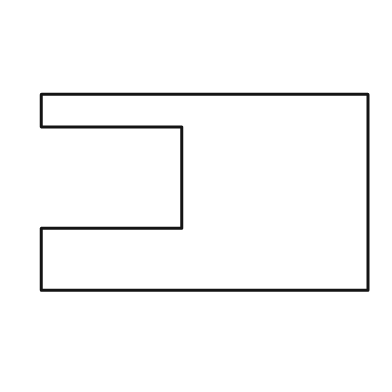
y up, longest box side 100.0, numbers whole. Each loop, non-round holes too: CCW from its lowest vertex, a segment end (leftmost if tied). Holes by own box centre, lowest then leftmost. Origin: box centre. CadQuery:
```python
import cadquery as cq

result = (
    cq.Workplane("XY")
    .moveTo(-50.0, -30.0)
    .lineTo(50.0, -30.0)
    .lineTo(50.0, 30.0)
    .lineTo(-50.0, 30.0)
    .lineTo(-50.0, 20.0)
    .lineTo(-7.0, 20.0)
    .lineTo(-7.0, -11.0)
    .lineTo(-50.0, -11.0)
    .close()
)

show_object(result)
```